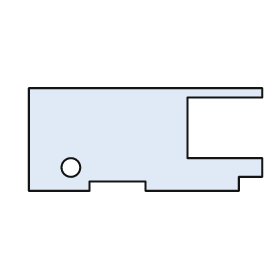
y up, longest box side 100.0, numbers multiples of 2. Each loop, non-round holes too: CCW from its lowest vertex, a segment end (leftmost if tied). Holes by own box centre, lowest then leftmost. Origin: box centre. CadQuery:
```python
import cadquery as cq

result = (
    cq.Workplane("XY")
    .moveTo(-50.0, -22.0)
    .lineTo(-24.0, -22.0)
    .lineTo(-24.0, -18.0)
    .lineTo(0.0, -18.0)
    .lineTo(0.0, -22.0)
    .lineTo(40.0, -22.0)
    .lineTo(40.0, -16.0)
    .lineTo(50.0, -16.0)
    .lineTo(50.0, -8.0)
    .lineTo(18.0, -8.0)
    .lineTo(18.0, 18.0)
    .lineTo(50.0, 18.0)
    .lineTo(50.0, 22.0)
    .lineTo(-50.0, 22.0)
    .close()
    .moveTo(-32.0, -12.0)
    .circle(4.0)
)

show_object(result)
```